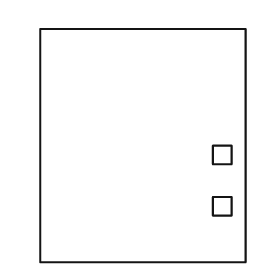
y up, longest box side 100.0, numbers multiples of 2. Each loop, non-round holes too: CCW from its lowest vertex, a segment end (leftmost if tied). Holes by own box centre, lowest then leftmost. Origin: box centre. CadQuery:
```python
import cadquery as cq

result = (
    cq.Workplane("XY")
    .moveTo(-44.0, -50.0)
    .lineTo(44.0, -50.0)
    .lineTo(44.0, 50.0)
    .lineTo(-44.0, 50.0)
    .close()
    .moveTo(30.0, -30.0)
    .lineTo(38.0, -30.0)
    .lineTo(38.0, -22.0)
    .lineTo(30.0, -22.0)
    .close()
    .moveTo(30.0, -8.0)
    .lineTo(38.0, -8.0)
    .lineTo(38.0, 0.0)
    .lineTo(30.0, 0.0)
    .close()
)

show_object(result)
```